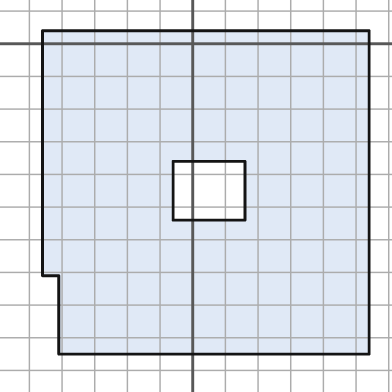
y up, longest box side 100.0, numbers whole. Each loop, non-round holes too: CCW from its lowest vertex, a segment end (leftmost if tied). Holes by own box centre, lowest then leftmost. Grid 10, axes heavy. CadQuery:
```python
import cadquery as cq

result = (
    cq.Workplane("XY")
    .moveTo(-41.0, -95.0)
    .lineTo(54.0, -95.0)
    .lineTo(54.0, 4.0)
    .lineTo(-46.0, 4.0)
    .lineTo(-46.0, -71.0)
    .lineTo(-41.0, -71.0)
    .close()
    .moveTo(-6.0, -54.0)
    .lineTo(16.0, -54.0)
    .lineTo(16.0, -36.0)
    .lineTo(-6.0, -36.0)
    .close()
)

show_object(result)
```